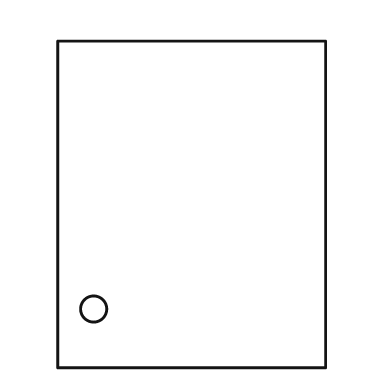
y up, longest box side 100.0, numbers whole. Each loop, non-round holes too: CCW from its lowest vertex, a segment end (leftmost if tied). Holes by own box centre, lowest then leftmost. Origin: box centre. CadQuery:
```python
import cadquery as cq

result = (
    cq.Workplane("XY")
    .moveTo(-41.0, -50.0)
    .lineTo(41.0, -50.0)
    .lineTo(41.0, 50.0)
    .lineTo(-41.0, 50.0)
    .close()
    .moveTo(-30.0, -32.0)
    .circle(4.0)
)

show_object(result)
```